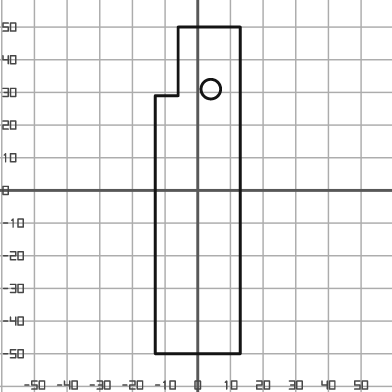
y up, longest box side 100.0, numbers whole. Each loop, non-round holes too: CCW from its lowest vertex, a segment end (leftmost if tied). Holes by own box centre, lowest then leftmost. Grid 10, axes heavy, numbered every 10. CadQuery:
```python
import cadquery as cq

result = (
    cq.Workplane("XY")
    .moveTo(-13.0, -50.0)
    .lineTo(13.0, -50.0)
    .lineTo(13.0, 50.0)
    .lineTo(-6.0, 50.0)
    .lineTo(-6.0, 29.0)
    .lineTo(-13.0, 29.0)
    .close()
    .moveTo(4.0, 31.0)
    .circle(3.0)
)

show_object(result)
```